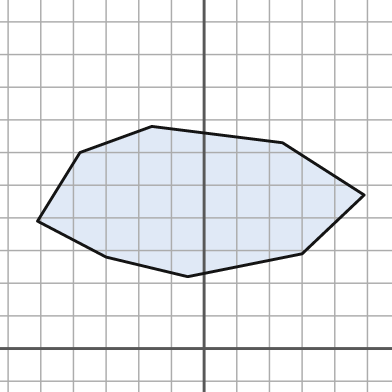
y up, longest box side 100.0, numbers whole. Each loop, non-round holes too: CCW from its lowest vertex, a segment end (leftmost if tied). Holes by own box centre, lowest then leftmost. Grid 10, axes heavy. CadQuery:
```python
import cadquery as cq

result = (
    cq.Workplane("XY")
    .moveTo(-5.0, 22.0)
    .lineTo(30.0, 29.0)
    .lineTo(49.0, 47.0)
    .lineTo(24.0, 63.0)
    .lineTo(-16.0, 68.0)
    .lineTo(-38.0, 60.0)
    .lineTo(-51.0, 39.0)
    .lineTo(-30.0, 28.0)
    .close()
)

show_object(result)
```